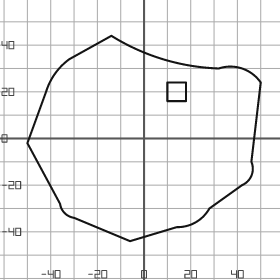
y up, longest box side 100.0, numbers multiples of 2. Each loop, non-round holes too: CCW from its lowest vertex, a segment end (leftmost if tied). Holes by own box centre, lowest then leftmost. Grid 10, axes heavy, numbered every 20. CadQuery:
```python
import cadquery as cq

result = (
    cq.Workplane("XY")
    .moveTo(-6.0, -44.0)
    .lineTo(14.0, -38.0)
    .threePointArc((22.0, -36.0), (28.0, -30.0))
    .lineTo(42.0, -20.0)
    .threePointArc((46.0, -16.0), (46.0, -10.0))
    .lineTo(50.0, 24.0)
    .threePointArc((42.0, 30.0), (32.0, 30.0))
    .threePointArc((8.0, 34.0), (-14.0, 44.0))
    .lineTo(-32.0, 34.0)
    .threePointArc((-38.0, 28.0), (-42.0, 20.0))
    .lineTo(-50.0, -2.0)
    .lineTo(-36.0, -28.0)
    .threePointArc((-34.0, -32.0), (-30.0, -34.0))
    .close()
    .moveTo(10.0, 16.0)
    .lineTo(18.0, 16.0)
    .lineTo(18.0, 24.0)
    .lineTo(10.0, 24.0)
    .close()
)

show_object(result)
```